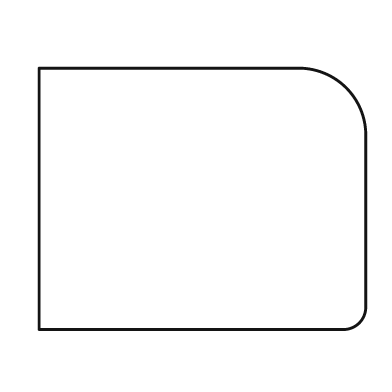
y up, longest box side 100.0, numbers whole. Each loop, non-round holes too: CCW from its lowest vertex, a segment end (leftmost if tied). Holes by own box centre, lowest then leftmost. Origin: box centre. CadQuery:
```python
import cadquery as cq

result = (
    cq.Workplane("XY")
    .moveTo(-50.0, -40.0)
    .lineTo(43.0, -40.0)
    .threePointArc((48.0, -38.0), (50.0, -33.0))
    .lineTo(50.0, 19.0)
    .threePointArc((44.0, 34.0), (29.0, 40.0))
    .lineTo(-50.0, 40.0)
    .close()
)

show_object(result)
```